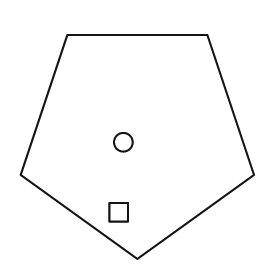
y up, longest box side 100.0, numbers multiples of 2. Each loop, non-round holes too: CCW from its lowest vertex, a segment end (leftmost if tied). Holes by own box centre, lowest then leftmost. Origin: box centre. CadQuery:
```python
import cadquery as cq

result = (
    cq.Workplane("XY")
    .moveTo(0.0, -48.0)
    .lineTo(50.0, -12.0)
    .lineTo(30.0, 48.0)
    .lineTo(-30.0, 48.0)
    .lineTo(-50.0, -12.0)
    .close()
    .moveTo(-12.0, -32.0)
    .lineTo(-4.0, -32.0)
    .lineTo(-4.0, -24.0)
    .lineTo(-12.0, -24.0)
    .close()
    .moveTo(-6.0, 2.0)
    .circle(4.0)
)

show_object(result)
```